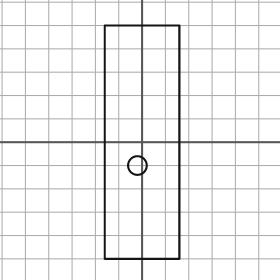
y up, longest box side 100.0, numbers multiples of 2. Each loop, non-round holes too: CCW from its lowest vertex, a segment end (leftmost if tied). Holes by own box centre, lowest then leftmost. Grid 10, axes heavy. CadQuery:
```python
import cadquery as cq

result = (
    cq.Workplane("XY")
    .moveTo(-16.0, -50.0)
    .lineTo(16.0, -50.0)
    .lineTo(16.0, 50.0)
    .lineTo(-16.0, 50.0)
    .close()
    .moveTo(-2.0, -10.0)
    .circle(4.0)
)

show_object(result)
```